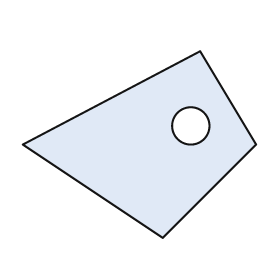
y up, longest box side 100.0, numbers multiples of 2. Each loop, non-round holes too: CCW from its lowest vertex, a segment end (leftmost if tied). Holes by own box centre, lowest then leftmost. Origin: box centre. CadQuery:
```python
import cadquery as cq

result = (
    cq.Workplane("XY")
    .moveTo(10.0, -40.0)
    .lineTo(50.0, 0.0)
    .lineTo(26.0, 40.0)
    .lineTo(-50.0, 0.0)
    .close()
    .moveTo(22.0, 8.0)
    .circle(8.0)
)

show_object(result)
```